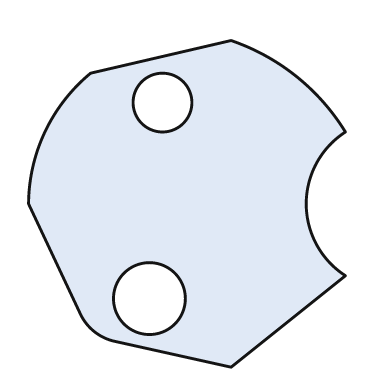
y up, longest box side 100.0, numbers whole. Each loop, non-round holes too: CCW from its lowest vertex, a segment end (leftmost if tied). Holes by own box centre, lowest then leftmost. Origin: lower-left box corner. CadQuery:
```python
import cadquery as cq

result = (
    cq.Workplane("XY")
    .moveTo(62.0, 0.0)
    .lineTo(97.0, 28.0)
    .threePointArc((85.0, 50.0), (97.0, 72.0))
    .threePointArc((82.0, 89.0), (62.0, 100.0))
    .lineTo(19.0, 90.0)
    .threePointArc((5.0, 72.0), (0.0, 50.0))
    .lineTo(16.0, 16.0)
    .threePointArc((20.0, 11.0), (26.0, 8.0))
    .close()
    .moveTo(37.0, 21.0)
    .circle(11.0)
    .moveTo(41.0, 81.0)
    .circle(9.0)
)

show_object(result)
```